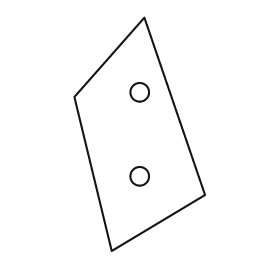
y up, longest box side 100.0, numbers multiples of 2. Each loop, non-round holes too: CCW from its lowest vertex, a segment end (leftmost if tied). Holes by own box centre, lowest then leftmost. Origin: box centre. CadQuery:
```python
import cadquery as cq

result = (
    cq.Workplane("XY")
    .moveTo(-12.0, -50.0)
    .lineTo(28.0, -26.0)
    .lineTo(2.0, 50.0)
    .lineTo(-28.0, 16.0)
    .close()
    .moveTo(0.0, -18.0)
    .circle(4.0)
    .moveTo(0.0, 18.0)
    .circle(4.0)
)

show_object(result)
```